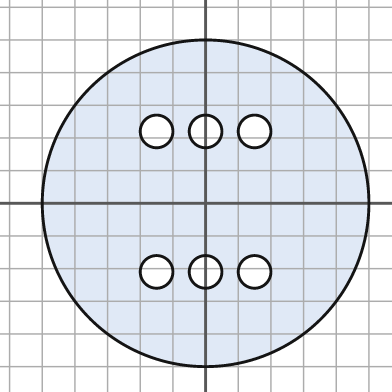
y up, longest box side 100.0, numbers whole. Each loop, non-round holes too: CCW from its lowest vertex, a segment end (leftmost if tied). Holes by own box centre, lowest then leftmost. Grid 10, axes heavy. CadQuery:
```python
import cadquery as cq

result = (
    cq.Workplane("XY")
    .moveTo(0.0, 0.0)
    .circle(50.0)
    .moveTo(-15.0, -21.0)
    .circle(5.0)
    .moveTo(0.0, -21.0)
    .circle(5.0)
    .moveTo(15.0, -21.0)
    .circle(5.0)
    .moveTo(-15.0, 22.0)
    .circle(5.0)
    .moveTo(0.0, 22.0)
    .circle(5.0)
    .moveTo(15.0, 22.0)
    .circle(5.0)
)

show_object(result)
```